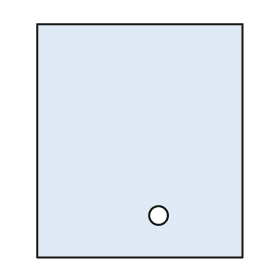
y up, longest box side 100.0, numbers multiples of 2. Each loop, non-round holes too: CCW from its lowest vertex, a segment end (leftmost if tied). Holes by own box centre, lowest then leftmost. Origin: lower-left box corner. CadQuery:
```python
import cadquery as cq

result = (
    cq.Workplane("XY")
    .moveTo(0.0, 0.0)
    .lineTo(88.0, 0.0)
    .lineTo(88.0, 100.0)
    .lineTo(0.0, 100.0)
    .close()
    .moveTo(52.0, 18.0)
    .circle(4.0)
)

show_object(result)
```